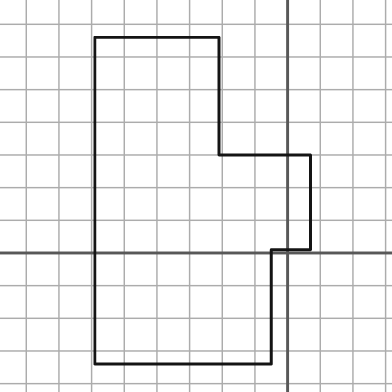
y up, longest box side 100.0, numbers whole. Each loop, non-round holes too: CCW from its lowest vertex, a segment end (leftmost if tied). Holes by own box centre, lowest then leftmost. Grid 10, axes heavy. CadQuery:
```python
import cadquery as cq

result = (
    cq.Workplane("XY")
    .moveTo(-59.0, -34.0)
    .lineTo(-5.0, -34.0)
    .lineTo(-5.0, 1.0)
    .lineTo(7.0, 1.0)
    .lineTo(7.0, 30.0)
    .lineTo(-21.0, 30.0)
    .lineTo(-21.0, 66.0)
    .lineTo(-59.0, 66.0)
    .close()
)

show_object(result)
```